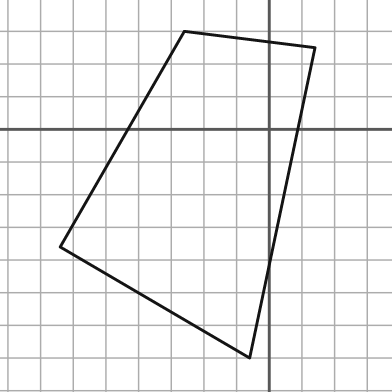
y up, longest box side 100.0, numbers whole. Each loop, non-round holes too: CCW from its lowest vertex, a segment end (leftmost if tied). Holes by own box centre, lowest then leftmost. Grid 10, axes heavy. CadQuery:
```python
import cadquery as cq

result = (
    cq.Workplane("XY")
    .moveTo(-6.0, -70.0)
    .lineTo(14.0, 25.0)
    .lineTo(-26.0, 30.0)
    .lineTo(-64.0, -36.0)
    .close()
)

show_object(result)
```